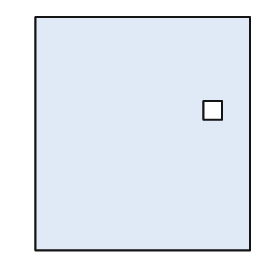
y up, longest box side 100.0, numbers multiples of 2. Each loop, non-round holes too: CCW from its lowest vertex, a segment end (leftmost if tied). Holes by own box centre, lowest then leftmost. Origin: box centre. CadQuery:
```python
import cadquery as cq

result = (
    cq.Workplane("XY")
    .moveTo(-46.0, -50.0)
    .lineTo(46.0, -50.0)
    .lineTo(46.0, 50.0)
    .lineTo(-46.0, 50.0)
    .close()
    .moveTo(26.0, 6.0)
    .lineTo(34.0, 6.0)
    .lineTo(34.0, 14.0)
    .lineTo(26.0, 14.0)
    .close()
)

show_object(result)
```